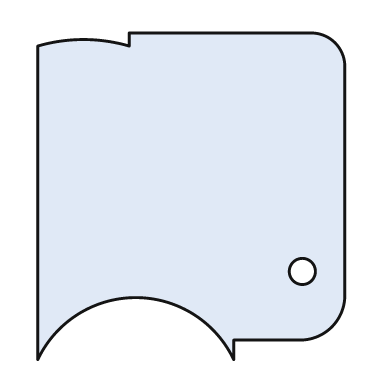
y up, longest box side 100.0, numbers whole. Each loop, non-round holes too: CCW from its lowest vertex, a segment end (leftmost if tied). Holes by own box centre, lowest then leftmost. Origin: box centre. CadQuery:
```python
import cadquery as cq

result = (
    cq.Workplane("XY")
    .moveTo(-47.0, -50.0)
    .threePointArc((-17.0, -31.0), (13.0, -50.0))
    .lineTo(13.0, -44.0)
    .lineTo(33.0, -44.0)
    .threePointArc((43.0, -40.0), (47.0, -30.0))
    .lineTo(47.0, 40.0)
    .threePointArc((44.0, 47.0), (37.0, 50.0))
    .lineTo(-19.0, 50.0)
    .lineTo(-19.0, 46.0)
    .threePointArc((-33.0, 48.0), (-47.0, 46.0))
    .close()
    .moveTo(34.0, -23.0)
    .circle(4.0)
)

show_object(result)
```